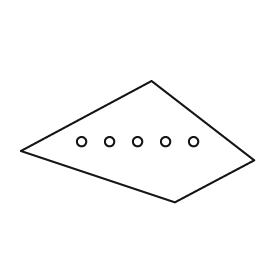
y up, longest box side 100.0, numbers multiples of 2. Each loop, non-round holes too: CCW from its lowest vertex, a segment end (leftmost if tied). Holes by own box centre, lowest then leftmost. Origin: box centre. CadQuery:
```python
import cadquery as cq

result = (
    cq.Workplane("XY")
    .moveTo(16.0, -26.0)
    .lineTo(50.0, -8.0)
    .lineTo(6.0, 26.0)
    .lineTo(-50.0, -4.0)
    .close()
    .moveTo(-24.0, 0.0)
    .circle(2.0)
    .moveTo(-12.0, 0.0)
    .circle(2.0)
    .moveTo(0.0, 0.0)
    .circle(2.0)
    .moveTo(12.0, 0.0)
    .circle(2.0)
    .moveTo(24.0, 0.0)
    .circle(2.0)
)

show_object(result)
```